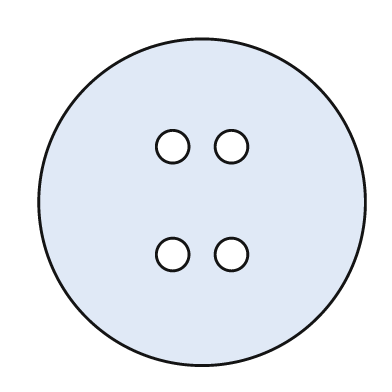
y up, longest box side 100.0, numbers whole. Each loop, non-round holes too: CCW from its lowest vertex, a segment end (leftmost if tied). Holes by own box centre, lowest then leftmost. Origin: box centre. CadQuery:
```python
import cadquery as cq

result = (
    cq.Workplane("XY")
    .moveTo(0.0, 0.0)
    .circle(50.0)
    .moveTo(-9.0, -16.0)
    .circle(5.0)
    .moveTo(9.0, -16.0)
    .circle(5.0)
    .moveTo(-9.0, 17.0)
    .circle(5.0)
    .moveTo(9.0, 17.0)
    .circle(5.0)
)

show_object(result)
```